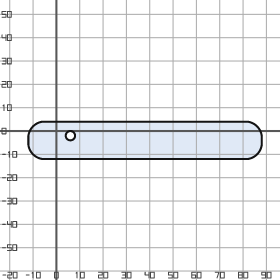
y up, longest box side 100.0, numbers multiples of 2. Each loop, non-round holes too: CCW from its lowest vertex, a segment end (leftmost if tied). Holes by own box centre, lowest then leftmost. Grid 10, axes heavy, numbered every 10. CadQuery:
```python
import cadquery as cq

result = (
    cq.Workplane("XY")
    .moveTo(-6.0, -12.0)
    .lineTo(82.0, -12.0)
    .threePointArc((86.0, -10.0), (88.0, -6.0))
    .lineTo(88.0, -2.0)
    .threePointArc((86.0, 2.0), (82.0, 4.0))
    .lineTo(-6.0, 4.0)
    .threePointArc((-10.0, 2.0), (-12.0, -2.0))
    .lineTo(-12.0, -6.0)
    .threePointArc((-10.0, -10.0), (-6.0, -12.0))
    .close()
    .moveTo(6.0, -2.0)
    .circle(2.0)
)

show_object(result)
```